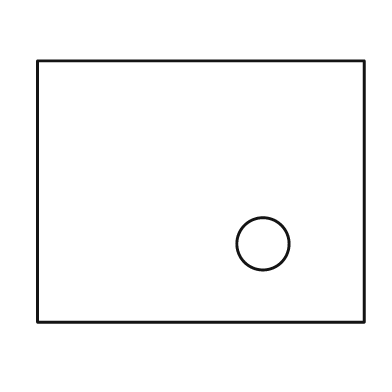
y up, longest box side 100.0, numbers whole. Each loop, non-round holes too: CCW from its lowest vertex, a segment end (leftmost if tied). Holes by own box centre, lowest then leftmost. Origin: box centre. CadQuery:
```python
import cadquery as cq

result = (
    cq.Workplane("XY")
    .moveTo(-50.0, -40.0)
    .lineTo(50.0, -40.0)
    .lineTo(50.0, 40.0)
    .lineTo(-50.0, 40.0)
    .close()
    .moveTo(19.0, -16.0)
    .circle(8.0)
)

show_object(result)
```